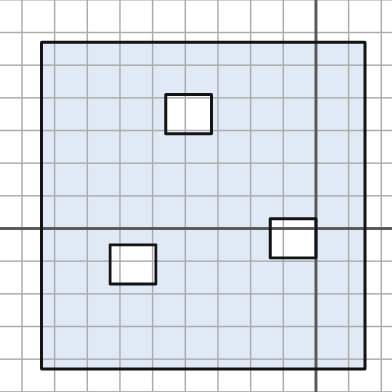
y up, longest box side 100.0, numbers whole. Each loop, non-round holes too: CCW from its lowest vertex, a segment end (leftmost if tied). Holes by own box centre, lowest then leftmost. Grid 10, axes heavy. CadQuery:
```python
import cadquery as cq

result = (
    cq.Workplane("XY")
    .moveTo(-84.0, -43.0)
    .lineTo(15.0, -43.0)
    .lineTo(15.0, 57.0)
    .lineTo(-84.0, 57.0)
    .close()
    .moveTo(-63.0, -17.0)
    .lineTo(-49.0, -17.0)
    .lineTo(-49.0, -5.0)
    .lineTo(-63.0, -5.0)
    .close()
    .moveTo(-14.0, -9.0)
    .lineTo(0.0, -9.0)
    .lineTo(0.0, 3.0)
    .lineTo(-14.0, 3.0)
    .close()
    .moveTo(-46.0, 29.0)
    .lineTo(-32.0, 29.0)
    .lineTo(-32.0, 41.0)
    .lineTo(-46.0, 41.0)
    .close()
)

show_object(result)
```